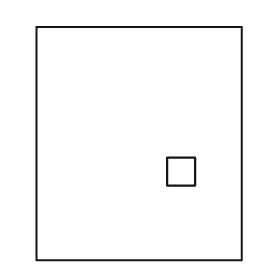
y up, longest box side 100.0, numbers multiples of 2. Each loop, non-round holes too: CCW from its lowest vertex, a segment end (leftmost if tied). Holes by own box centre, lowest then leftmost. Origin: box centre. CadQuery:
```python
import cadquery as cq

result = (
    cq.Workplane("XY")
    .moveTo(-44.0, -50.0)
    .lineTo(44.0, -50.0)
    .lineTo(44.0, 50.0)
    .lineTo(-44.0, 50.0)
    .close()
    .moveTo(12.0, -18.0)
    .lineTo(24.0, -18.0)
    .lineTo(24.0, -6.0)
    .lineTo(12.0, -6.0)
    .close()
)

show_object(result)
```